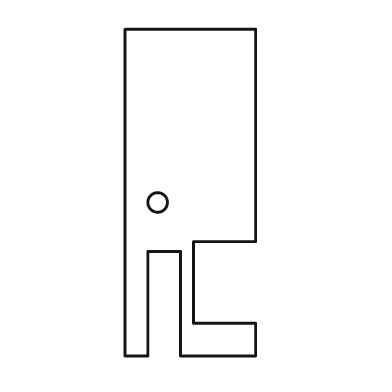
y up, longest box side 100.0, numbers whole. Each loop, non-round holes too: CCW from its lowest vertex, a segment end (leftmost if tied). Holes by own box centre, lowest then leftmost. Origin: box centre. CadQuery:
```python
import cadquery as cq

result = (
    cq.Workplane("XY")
    .moveTo(-20.0, -50.0)
    .lineTo(-13.0, -50.0)
    .lineTo(-13.0, -18.0)
    .lineTo(-3.0, -18.0)
    .lineTo(-3.0, -50.0)
    .lineTo(20.0, -50.0)
    .lineTo(20.0, -40.0)
    .lineTo(1.0, -40.0)
    .lineTo(1.0, -15.0)
    .lineTo(20.0, -15.0)
    .lineTo(20.0, 50.0)
    .lineTo(-20.0, 50.0)
    .close()
    .moveTo(-10.0, -3.0)
    .circle(3.0)
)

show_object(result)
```